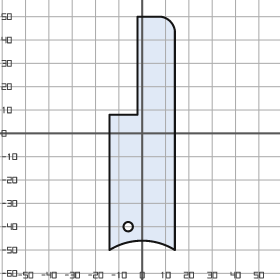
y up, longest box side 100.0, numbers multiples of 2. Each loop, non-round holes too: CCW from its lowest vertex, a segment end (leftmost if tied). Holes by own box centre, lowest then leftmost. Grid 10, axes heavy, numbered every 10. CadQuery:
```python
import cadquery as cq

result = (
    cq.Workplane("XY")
    .moveTo(-14.0, -50.0)
    .threePointArc((0.0, -46.0), (14.0, -50.0))
    .lineTo(14.0, 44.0)
    .threePointArc((12.0, 48.0), (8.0, 50.0))
    .lineTo(-2.0, 50.0)
    .lineTo(-2.0, 8.0)
    .lineTo(-14.0, 8.0)
    .close()
    .moveTo(-6.0, -40.0)
    .circle(2.0)
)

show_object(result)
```